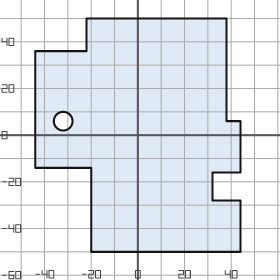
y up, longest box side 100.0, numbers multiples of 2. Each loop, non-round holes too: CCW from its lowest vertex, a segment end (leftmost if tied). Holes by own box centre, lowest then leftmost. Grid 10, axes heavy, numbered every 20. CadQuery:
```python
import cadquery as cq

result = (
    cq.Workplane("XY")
    .moveTo(-20.0, -50.0)
    .lineTo(44.0, -50.0)
    .lineTo(44.0, -28.0)
    .lineTo(32.0, -28.0)
    .lineTo(32.0, -16.0)
    .lineTo(44.0, -16.0)
    .lineTo(44.0, 6.0)
    .lineTo(38.0, 6.0)
    .lineTo(38.0, 50.0)
    .lineTo(-22.0, 50.0)
    .lineTo(-22.0, 36.0)
    .lineTo(-44.0, 36.0)
    .lineTo(-44.0, -14.0)
    .lineTo(-20.0, -14.0)
    .close()
    .moveTo(-32.0, 6.0)
    .circle(4.0)
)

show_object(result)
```